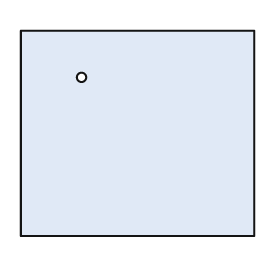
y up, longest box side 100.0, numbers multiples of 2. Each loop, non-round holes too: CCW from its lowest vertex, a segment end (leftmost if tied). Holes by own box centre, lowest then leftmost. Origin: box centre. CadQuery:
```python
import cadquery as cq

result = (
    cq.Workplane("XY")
    .moveTo(-50.0, -44.0)
    .lineTo(50.0, -44.0)
    .lineTo(50.0, 44.0)
    .lineTo(-50.0, 44.0)
    .close()
    .moveTo(-24.0, 24.0)
    .circle(2.0)
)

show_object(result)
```